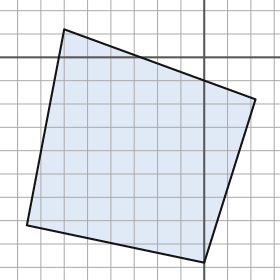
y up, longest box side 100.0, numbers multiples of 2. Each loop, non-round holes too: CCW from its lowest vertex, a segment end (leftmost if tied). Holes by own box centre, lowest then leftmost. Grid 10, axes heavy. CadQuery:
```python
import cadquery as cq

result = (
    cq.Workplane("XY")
    .moveTo(0.0, -88.0)
    .lineTo(22.0, -18.0)
    .lineTo(-60.0, 12.0)
    .lineTo(-76.0, -72.0)
    .close()
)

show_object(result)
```